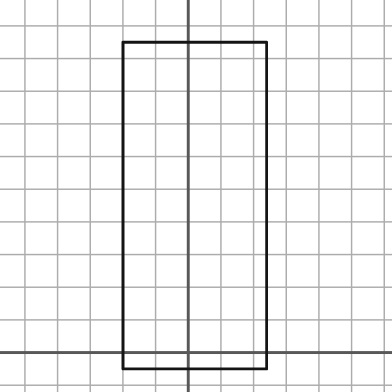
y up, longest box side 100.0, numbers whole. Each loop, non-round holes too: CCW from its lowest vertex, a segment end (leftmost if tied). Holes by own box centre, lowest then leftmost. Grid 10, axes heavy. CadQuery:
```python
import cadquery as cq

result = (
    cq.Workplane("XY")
    .moveTo(-20.0, -5.0)
    .lineTo(24.0, -5.0)
    .lineTo(24.0, 95.0)
    .lineTo(-20.0, 95.0)
    .close()
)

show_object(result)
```